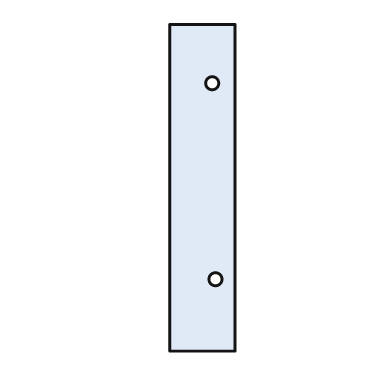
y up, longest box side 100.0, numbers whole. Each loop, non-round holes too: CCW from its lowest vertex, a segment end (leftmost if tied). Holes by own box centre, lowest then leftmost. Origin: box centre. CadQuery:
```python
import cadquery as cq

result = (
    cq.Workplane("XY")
    .moveTo(-10.0, -50.0)
    .lineTo(10.0, -50.0)
    .lineTo(10.0, 50.0)
    .lineTo(-10.0, 50.0)
    .close()
    .moveTo(4.0, -28.0)
    .circle(2.0)
    .moveTo(3.0, 32.0)
    .circle(2.0)
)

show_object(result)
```